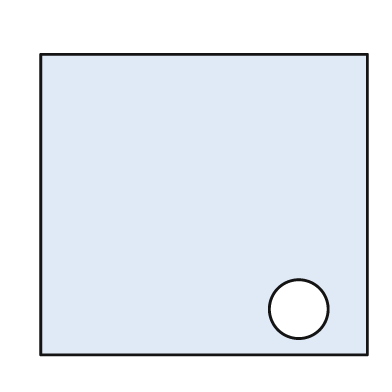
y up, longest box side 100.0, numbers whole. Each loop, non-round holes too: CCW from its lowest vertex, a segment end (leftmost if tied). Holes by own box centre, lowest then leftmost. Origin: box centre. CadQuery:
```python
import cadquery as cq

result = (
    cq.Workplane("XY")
    .moveTo(-50.0, -46.0)
    .lineTo(50.0, -46.0)
    .lineTo(50.0, 46.0)
    .lineTo(-50.0, 46.0)
    .close()
    .moveTo(29.0, -32.0)
    .circle(9.0)
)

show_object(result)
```